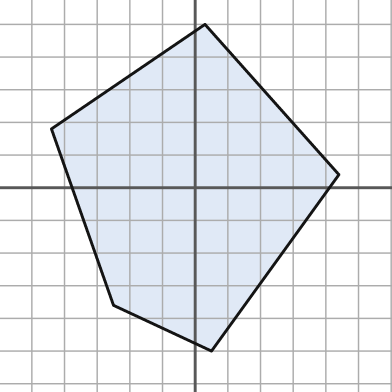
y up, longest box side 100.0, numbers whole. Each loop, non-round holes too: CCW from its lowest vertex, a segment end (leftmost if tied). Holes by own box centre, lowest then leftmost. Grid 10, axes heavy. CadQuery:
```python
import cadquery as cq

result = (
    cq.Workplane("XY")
    .moveTo(5.0, -50.0)
    .lineTo(44.0, 4.0)
    .lineTo(3.0, 50.0)
    .lineTo(-44.0, 18.0)
    .lineTo(-25.0, -36.0)
    .close()
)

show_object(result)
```